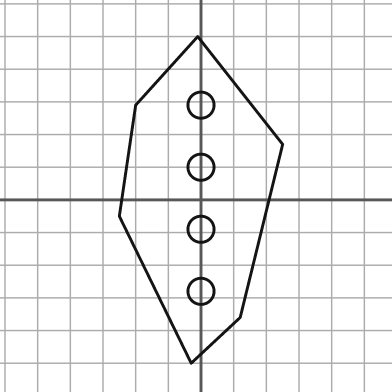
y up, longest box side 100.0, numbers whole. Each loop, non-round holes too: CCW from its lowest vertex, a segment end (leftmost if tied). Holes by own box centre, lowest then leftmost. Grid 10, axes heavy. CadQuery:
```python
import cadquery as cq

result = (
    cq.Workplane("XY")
    .moveTo(-3.0, -50.0)
    .lineTo(12.0, -36.0)
    .lineTo(25.0, 17.0)
    .lineTo(-1.0, 50.0)
    .lineTo(-20.0, 29.0)
    .lineTo(-25.0, -5.0)
    .close()
    .moveTo(0.0, -28.0)
    .circle(4.0)
    .moveTo(0.0, -9.0)
    .circle(4.0)
    .moveTo(0.0, 10.0)
    .circle(4.0)
    .moveTo(0.0, 29.0)
    .circle(4.0)
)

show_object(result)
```